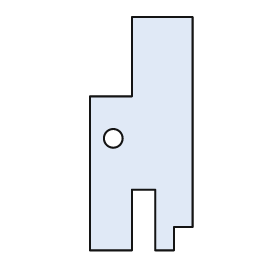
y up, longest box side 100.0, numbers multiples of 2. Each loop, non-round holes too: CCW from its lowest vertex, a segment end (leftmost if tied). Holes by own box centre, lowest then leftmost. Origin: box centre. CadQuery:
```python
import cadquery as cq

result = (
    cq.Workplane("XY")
    .moveTo(-22.0, -50.0)
    .lineTo(-4.0, -50.0)
    .lineTo(-4.0, -24.0)
    .lineTo(6.0, -24.0)
    .lineTo(6.0, -50.0)
    .lineTo(14.0, -50.0)
    .lineTo(14.0, -40.0)
    .lineTo(22.0, -40.0)
    .lineTo(22.0, 50.0)
    .lineTo(-4.0, 50.0)
    .lineTo(-4.0, 16.0)
    .lineTo(-22.0, 16.0)
    .close()
    .moveTo(-12.0, -2.0)
    .circle(4.0)
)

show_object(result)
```